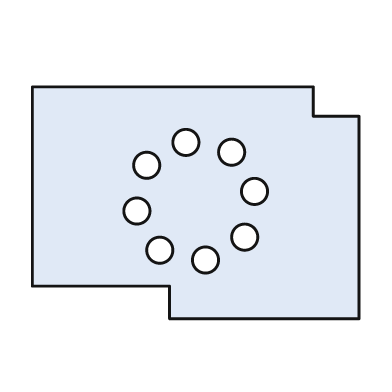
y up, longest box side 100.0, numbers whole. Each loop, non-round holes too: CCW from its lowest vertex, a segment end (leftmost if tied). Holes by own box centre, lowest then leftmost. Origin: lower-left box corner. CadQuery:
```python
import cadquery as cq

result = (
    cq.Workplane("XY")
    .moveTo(42.0, 0.0)
    .lineTo(100.0, 0.0)
    .lineTo(100.0, 62.0)
    .lineTo(86.0, 62.0)
    .lineTo(86.0, 71.0)
    .lineTo(0.0, 71.0)
    .lineTo(0.0, 10.0)
    .lineTo(42.0, 10.0)
    .close()
    .moveTo(53.0, 18.0)
    .circle(4.0)
    .moveTo(39.0, 21.0)
    .circle(4.0)
    .moveTo(65.0, 25.0)
    .circle(4.0)
    .moveTo(32.0, 33.0)
    .circle(4.0)
    .moveTo(68.0, 39.0)
    .circle(4.0)
    .moveTo(35.0, 47.0)
    .circle(4.0)
    .moveTo(61.0, 51.0)
    .circle(4.0)
    .moveTo(47.0, 54.0)
    .circle(4.0)
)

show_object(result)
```